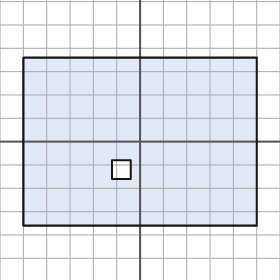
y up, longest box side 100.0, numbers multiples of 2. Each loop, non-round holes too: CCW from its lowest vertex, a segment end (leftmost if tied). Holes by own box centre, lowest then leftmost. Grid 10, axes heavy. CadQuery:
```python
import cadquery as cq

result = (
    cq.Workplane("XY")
    .moveTo(-50.0, -36.0)
    .lineTo(50.0, -36.0)
    .lineTo(50.0, 36.0)
    .lineTo(-50.0, 36.0)
    .close()
    .moveTo(-12.0, -16.0)
    .lineTo(-4.0, -16.0)
    .lineTo(-4.0, -8.0)
    .lineTo(-12.0, -8.0)
    .close()
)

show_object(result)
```